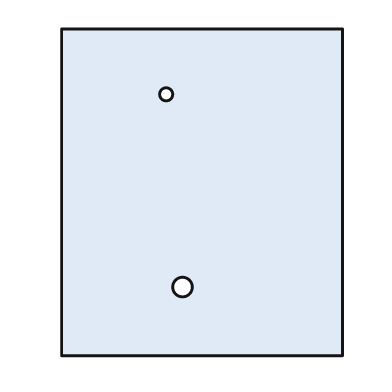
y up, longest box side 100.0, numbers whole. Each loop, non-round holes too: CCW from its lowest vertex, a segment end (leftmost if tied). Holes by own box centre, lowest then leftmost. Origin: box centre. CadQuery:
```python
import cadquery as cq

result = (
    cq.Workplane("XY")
    .moveTo(-43.0, -50.0)
    .lineTo(43.0, -50.0)
    .lineTo(43.0, 50.0)
    .lineTo(-43.0, 50.0)
    .close()
    .moveTo(-6.0, -29.0)
    .circle(3.0)
    .moveTo(-11.0, 30.0)
    .circle(2.0)
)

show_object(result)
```